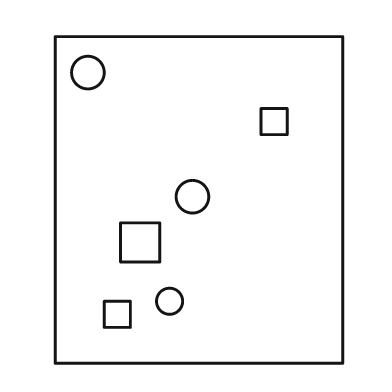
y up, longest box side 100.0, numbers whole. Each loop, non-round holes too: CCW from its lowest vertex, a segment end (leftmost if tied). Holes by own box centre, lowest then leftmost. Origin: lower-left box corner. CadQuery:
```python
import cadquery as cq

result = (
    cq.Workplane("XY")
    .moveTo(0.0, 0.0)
    .lineTo(88.0, 0.0)
    .lineTo(88.0, 100.0)
    .lineTo(0.0, 100.0)
    .close()
    .moveTo(15.0, 11.0)
    .lineTo(23.0, 11.0)
    .lineTo(23.0, 19.0)
    .lineTo(15.0, 19.0)
    .close()
    .moveTo(35.0, 19.0)
    .circle(4.0)
    .moveTo(20.0, 31.0)
    .lineTo(32.0, 31.0)
    .lineTo(32.0, 43.0)
    .lineTo(20.0, 43.0)
    .close()
    .moveTo(42.0, 51.0)
    .circle(5.0)
    .moveTo(63.0, 70.0)
    .lineTo(71.0, 70.0)
    .lineTo(71.0, 78.0)
    .lineTo(63.0, 78.0)
    .close()
    .moveTo(10.0, 89.0)
    .circle(5.0)
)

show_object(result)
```